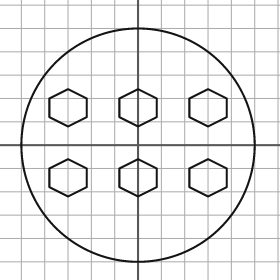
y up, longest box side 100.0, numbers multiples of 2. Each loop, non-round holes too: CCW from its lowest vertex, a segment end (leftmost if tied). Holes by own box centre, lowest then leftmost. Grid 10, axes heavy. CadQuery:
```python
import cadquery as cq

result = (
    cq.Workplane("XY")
    .moveTo(0.0, 0.0)
    .circle(50.0)
    .moveTo(-30.0, -22.0)
    .lineTo(-22.0, -18.0)
    .lineTo(-22.0, -10.0)
    .lineTo(-30.0, -6.0)
    .lineTo(-38.0, -10.0)
    .lineTo(-38.0, -18.0)
    .close()
    .moveTo(0.0, -22.0)
    .lineTo(8.0, -18.0)
    .lineTo(8.0, -10.0)
    .lineTo(0.0, -6.0)
    .lineTo(-8.0, -10.0)
    .lineTo(-8.0, -18.0)
    .close()
    .moveTo(30.0, -22.0)
    .lineTo(38.0, -18.0)
    .lineTo(38.0, -10.0)
    .lineTo(30.0, -6.0)
    .lineTo(22.0, -10.0)
    .lineTo(22.0, -18.0)
    .close()
    .moveTo(-30.0, 8.0)
    .lineTo(-22.0, 12.0)
    .lineTo(-22.0, 20.0)
    .lineTo(-30.0, 24.0)
    .lineTo(-38.0, 20.0)
    .lineTo(-38.0, 12.0)
    .close()
    .moveTo(0.0, 8.0)
    .lineTo(8.0, 12.0)
    .lineTo(8.0, 20.0)
    .lineTo(0.0, 24.0)
    .lineTo(-8.0, 20.0)
    .lineTo(-8.0, 12.0)
    .close()
    .moveTo(30.0, 8.0)
    .lineTo(38.0, 12.0)
    .lineTo(38.0, 20.0)
    .lineTo(30.0, 24.0)
    .lineTo(22.0, 20.0)
    .lineTo(22.0, 12.0)
    .close()
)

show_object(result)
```